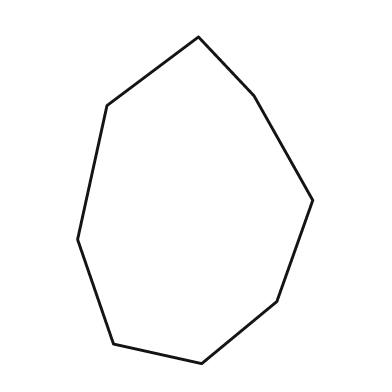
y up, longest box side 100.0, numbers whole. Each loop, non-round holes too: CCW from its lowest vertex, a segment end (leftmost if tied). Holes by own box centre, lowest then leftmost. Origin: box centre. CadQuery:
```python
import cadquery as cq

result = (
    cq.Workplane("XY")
    .moveTo(2.0, -50.0)
    .lineTo(25.0, -31.0)
    .lineTo(36.0, 0.0)
    .lineTo(18.0, 32.0)
    .lineTo(1.0, 50.0)
    .lineTo(-27.0, 29.0)
    .lineTo(-36.0, -12.0)
    .lineTo(-25.0, -44.0)
    .close()
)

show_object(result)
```